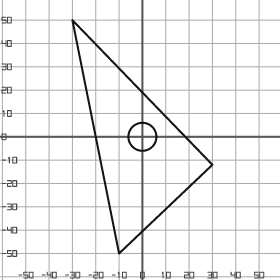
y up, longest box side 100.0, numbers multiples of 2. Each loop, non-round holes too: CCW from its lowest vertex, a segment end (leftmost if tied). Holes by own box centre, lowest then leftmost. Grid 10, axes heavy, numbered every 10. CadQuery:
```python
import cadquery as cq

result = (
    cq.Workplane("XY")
    .moveTo(-10.0, -50.0)
    .lineTo(30.0, -12.0)
    .lineTo(-30.0, 50.0)
    .close()
    .moveTo(0.0, 0.0)
    .circle(6.0)
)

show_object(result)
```